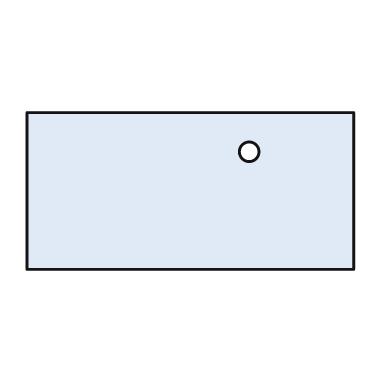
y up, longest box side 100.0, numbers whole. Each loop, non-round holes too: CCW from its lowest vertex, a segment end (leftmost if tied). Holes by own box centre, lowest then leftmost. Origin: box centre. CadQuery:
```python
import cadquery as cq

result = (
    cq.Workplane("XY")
    .moveTo(-50.0, -24.0)
    .lineTo(50.0, -24.0)
    .lineTo(50.0, 24.0)
    .lineTo(-50.0, 24.0)
    .close()
    .moveTo(18.0, 12.0)
    .circle(3.0)
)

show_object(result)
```